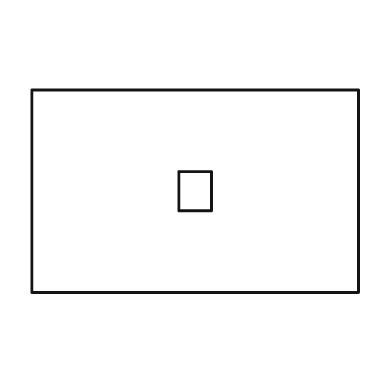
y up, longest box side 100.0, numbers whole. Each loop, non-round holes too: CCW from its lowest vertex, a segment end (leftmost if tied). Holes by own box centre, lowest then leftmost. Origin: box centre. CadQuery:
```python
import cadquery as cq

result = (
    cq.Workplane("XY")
    .moveTo(-50.0, -31.0)
    .lineTo(50.0, -31.0)
    .lineTo(50.0, 31.0)
    .lineTo(-50.0, 31.0)
    .close()
    .moveTo(-5.0, -6.0)
    .lineTo(5.0, -6.0)
    .lineTo(5.0, 6.0)
    .lineTo(-5.0, 6.0)
    .close()
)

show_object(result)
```